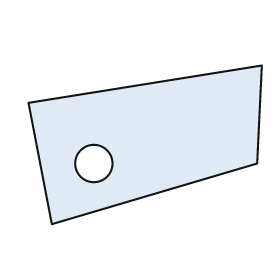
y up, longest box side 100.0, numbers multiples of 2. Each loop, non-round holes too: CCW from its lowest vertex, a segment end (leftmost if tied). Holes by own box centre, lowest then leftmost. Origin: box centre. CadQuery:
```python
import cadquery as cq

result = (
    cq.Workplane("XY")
    .moveTo(-40.0, -34.0)
    .lineTo(48.0, -8.0)
    .lineTo(50.0, 34.0)
    .lineTo(-50.0, 18.0)
    .close()
    .moveTo(-22.0, -8.0)
    .circle(8.0)
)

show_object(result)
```